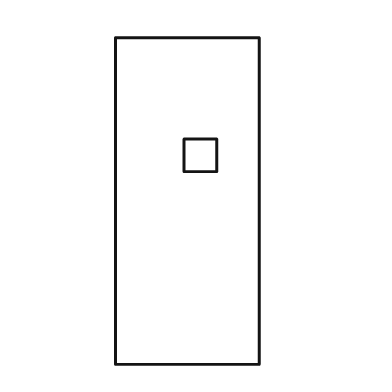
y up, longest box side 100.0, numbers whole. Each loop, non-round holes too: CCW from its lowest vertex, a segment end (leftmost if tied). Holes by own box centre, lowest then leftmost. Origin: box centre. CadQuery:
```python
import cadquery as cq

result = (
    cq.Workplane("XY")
    .moveTo(-22.0, -50.0)
    .lineTo(22.0, -50.0)
    .lineTo(22.0, 50.0)
    .lineTo(-22.0, 50.0)
    .close()
    .moveTo(-1.0, 9.0)
    .lineTo(9.0, 9.0)
    .lineTo(9.0, 19.0)
    .lineTo(-1.0, 19.0)
    .close()
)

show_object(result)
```